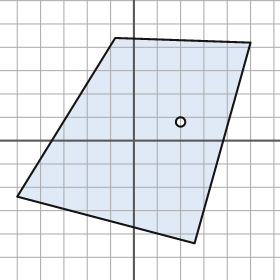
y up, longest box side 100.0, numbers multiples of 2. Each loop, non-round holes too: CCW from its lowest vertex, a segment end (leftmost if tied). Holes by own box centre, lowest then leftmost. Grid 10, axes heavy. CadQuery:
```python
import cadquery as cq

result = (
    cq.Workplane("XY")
    .moveTo(26.0, -44.0)
    .lineTo(50.0, 42.0)
    .lineTo(-8.0, 44.0)
    .lineTo(-50.0, -24.0)
    .close()
    .moveTo(20.0, 8.0)
    .circle(2.0)
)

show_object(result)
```